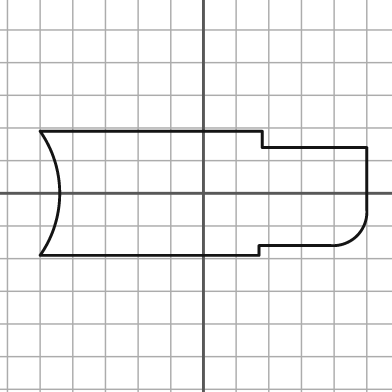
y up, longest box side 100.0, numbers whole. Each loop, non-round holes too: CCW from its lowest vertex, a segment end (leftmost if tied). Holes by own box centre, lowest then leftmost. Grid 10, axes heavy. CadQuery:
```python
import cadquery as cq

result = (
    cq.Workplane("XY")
    .moveTo(-50.0, -19.0)
    .lineTo(17.0, -19.0)
    .lineTo(17.0, -16.0)
    .lineTo(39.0, -16.0)
    .threePointArc((47.0, -13.0), (50.0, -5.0))
    .lineTo(50.0, 14.0)
    .lineTo(18.0, 14.0)
    .lineTo(18.0, 19.0)
    .lineTo(-50.0, 19.0)
    .threePointArc((-44.0, 0.0), (-50.0, -19.0))
    .close()
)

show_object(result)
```